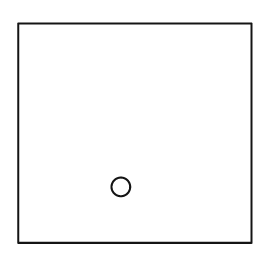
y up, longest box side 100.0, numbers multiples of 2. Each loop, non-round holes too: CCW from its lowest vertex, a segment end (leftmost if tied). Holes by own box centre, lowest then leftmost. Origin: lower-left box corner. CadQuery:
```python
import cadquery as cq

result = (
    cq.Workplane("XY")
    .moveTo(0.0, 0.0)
    .lineTo(100.0, 0.0)
    .lineTo(100.0, 94.0)
    .lineTo(0.0, 94.0)
    .close()
    .moveTo(44.0, 24.0)
    .circle(4.0)
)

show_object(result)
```